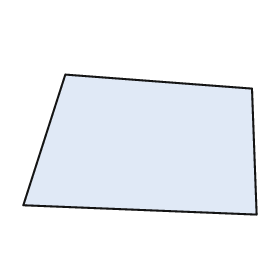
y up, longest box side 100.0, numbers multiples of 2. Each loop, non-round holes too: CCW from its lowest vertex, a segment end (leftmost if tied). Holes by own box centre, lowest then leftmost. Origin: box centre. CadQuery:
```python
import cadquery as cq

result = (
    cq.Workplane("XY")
    .moveTo(50.0, -30.0)
    .lineTo(48.0, 24.0)
    .lineTo(-32.0, 30.0)
    .lineTo(-50.0, -26.0)
    .close()
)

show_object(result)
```